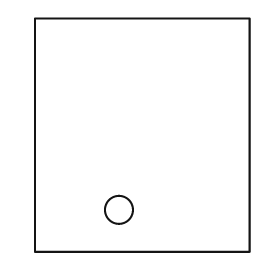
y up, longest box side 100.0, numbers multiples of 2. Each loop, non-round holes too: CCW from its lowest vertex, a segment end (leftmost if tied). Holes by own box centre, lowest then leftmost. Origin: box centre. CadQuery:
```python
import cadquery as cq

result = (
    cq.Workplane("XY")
    .moveTo(-46.0, -50.0)
    .lineTo(46.0, -50.0)
    .lineTo(46.0, 50.0)
    .lineTo(-46.0, 50.0)
    .close()
    .moveTo(-10.0, -32.0)
    .circle(6.0)
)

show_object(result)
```